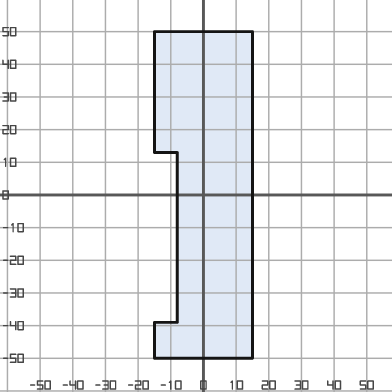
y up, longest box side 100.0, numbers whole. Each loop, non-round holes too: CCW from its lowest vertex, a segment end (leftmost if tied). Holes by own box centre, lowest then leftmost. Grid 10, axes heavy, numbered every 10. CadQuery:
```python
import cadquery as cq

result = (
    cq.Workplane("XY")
    .moveTo(-15.0, -50.0)
    .lineTo(15.0, -50.0)
    .lineTo(15.0, 50.0)
    .lineTo(-15.0, 50.0)
    .lineTo(-15.0, 13.0)
    .lineTo(-8.0, 13.0)
    .lineTo(-8.0, -39.0)
    .lineTo(-15.0, -39.0)
    .close()
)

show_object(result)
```